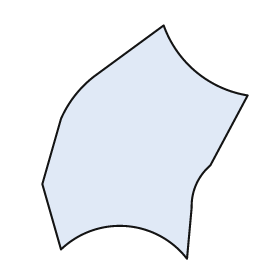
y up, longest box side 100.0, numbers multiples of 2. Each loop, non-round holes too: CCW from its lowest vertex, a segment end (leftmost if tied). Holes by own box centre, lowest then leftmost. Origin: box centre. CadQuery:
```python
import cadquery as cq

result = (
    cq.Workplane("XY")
    .moveTo(18.0, -50.0)
    .lineTo(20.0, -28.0)
    .threePointArc((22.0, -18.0), (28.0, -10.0))
    .lineTo(44.0, 20.0)
    .threePointArc((22.0, 30.0), (8.0, 50.0))
    .lineTo(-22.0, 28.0)
    .threePointArc((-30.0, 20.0), (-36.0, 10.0))
    .lineTo(-44.0, -18.0)
    .lineTo(-36.0, -46.0)
    .threePointArc((-8.0, -36.0), (18.0, -50.0))
    .close()
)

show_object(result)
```